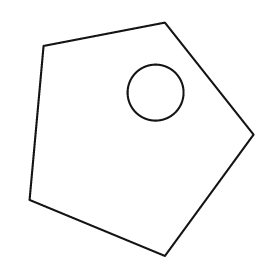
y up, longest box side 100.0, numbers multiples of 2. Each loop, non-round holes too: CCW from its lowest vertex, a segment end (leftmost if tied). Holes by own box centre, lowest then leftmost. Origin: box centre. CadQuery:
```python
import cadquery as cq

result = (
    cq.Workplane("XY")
    .moveTo(10.0, -50.0)
    .lineTo(48.0, 2.0)
    .lineTo(10.0, 50.0)
    .lineTo(-42.0, 40.0)
    .lineTo(-48.0, -26.0)
    .close()
    .moveTo(6.0, 20.0)
    .circle(12.0)
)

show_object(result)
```